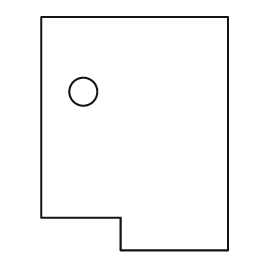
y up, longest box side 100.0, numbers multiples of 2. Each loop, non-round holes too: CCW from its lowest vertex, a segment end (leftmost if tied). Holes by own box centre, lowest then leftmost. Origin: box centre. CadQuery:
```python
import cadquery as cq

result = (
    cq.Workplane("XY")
    .moveTo(-6.0, -50.0)
    .lineTo(40.0, -50.0)
    .lineTo(40.0, 50.0)
    .lineTo(-40.0, 50.0)
    .lineTo(-40.0, -36.0)
    .lineTo(-6.0, -36.0)
    .close()
    .moveTo(-22.0, 18.0)
    .circle(6.0)
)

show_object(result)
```